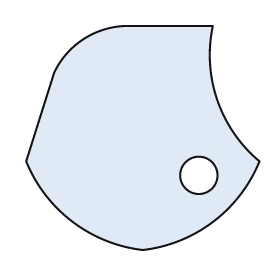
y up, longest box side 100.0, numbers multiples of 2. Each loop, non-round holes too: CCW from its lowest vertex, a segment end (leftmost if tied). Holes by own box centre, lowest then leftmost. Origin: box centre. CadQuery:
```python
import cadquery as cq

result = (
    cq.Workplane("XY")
    .moveTo(0.0, -48.0)
    .threePointArc((30.0, -36.0), (50.0, -10.0))
    .threePointArc((32.0, 16.0), (30.0, 48.0))
    .lineTo(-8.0, 48.0)
    .threePointArc((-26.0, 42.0), (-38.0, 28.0))
    .lineTo(-50.0, -10.0)
    .threePointArc((-30.0, -36.0), (0.0, -48.0))
    .close()
    .moveTo(24.0, -16.0)
    .circle(8.0)
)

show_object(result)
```